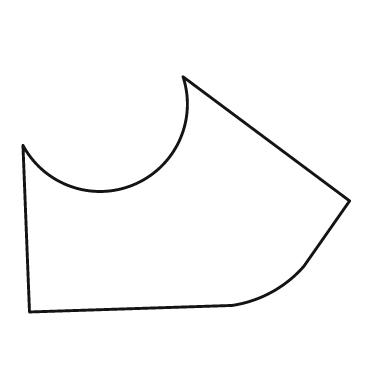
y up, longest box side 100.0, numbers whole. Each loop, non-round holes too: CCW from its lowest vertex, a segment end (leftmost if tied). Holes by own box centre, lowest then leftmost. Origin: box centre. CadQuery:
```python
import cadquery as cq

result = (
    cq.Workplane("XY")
    .moveTo(-48.0, -36.0)
    .lineTo(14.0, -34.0)
    .threePointArc((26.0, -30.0), (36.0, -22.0))
    .lineTo(50.0, -2.0)
    .lineTo(-1.0, 36.0)
    .threePointArc((-16.0, 3.0), (-50.0, 15.0))
    .close()
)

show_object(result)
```